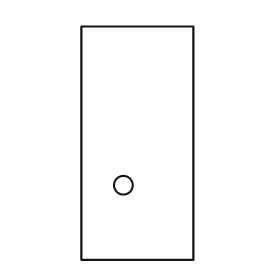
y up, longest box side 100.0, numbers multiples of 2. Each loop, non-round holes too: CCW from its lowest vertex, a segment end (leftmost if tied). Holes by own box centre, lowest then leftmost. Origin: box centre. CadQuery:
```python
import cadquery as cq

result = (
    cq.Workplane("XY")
    .moveTo(-24.0, -50.0)
    .lineTo(24.0, -50.0)
    .lineTo(24.0, 50.0)
    .lineTo(-24.0, 50.0)
    .close()
    .moveTo(-6.0, -18.0)
    .circle(4.0)
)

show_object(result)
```